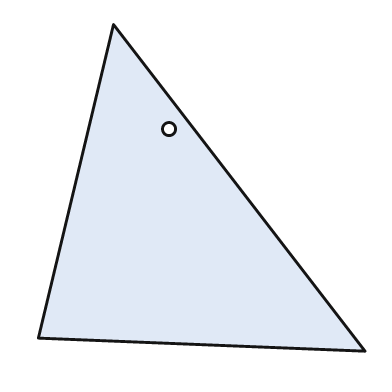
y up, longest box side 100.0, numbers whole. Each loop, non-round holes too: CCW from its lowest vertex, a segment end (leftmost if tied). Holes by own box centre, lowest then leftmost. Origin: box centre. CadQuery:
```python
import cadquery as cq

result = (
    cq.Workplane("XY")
    .moveTo(50.0, -50.0)
    .lineTo(-27.0, 50.0)
    .lineTo(-50.0, -46.0)
    .close()
    .moveTo(-10.0, 18.0)
    .circle(2.0)
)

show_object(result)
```